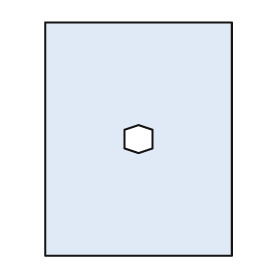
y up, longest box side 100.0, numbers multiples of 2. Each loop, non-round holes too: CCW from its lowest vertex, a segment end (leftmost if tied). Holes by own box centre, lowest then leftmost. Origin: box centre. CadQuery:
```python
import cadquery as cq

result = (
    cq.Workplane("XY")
    .moveTo(-40.0, -50.0)
    .lineTo(40.0, -50.0)
    .lineTo(40.0, 50.0)
    .lineTo(-40.0, 50.0)
    .close()
    .moveTo(0.0, -6.0)
    .lineTo(6.0, -4.0)
    .lineTo(6.0, 4.0)
    .lineTo(0.0, 6.0)
    .lineTo(-6.0, 4.0)
    .lineTo(-6.0, -4.0)
    .close()
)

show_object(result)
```